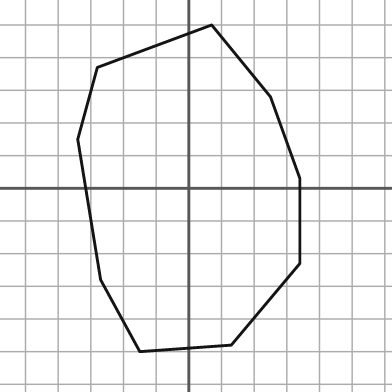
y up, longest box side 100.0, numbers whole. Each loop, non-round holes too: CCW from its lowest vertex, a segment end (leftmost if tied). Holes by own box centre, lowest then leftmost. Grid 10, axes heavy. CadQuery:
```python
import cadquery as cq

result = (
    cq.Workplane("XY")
    .moveTo(-15.0, -50.0)
    .lineTo(13.0, -48.0)
    .lineTo(34.0, -23.0)
    .lineTo(34.0, 3.0)
    .lineTo(25.0, 28.0)
    .lineTo(7.0, 50.0)
    .lineTo(-28.0, 37.0)
    .lineTo(-34.0, 15.0)
    .lineTo(-27.0, -28.0)
    .close()
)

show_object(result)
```